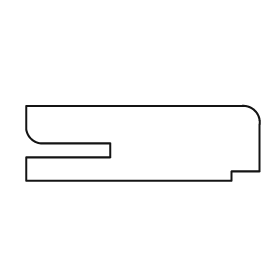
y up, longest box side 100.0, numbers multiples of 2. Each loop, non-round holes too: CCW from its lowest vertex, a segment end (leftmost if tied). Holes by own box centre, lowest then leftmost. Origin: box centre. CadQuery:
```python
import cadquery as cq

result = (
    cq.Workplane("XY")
    .moveTo(-50.0, -16.0)
    .lineTo(38.0, -16.0)
    .lineTo(38.0, -12.0)
    .lineTo(50.0, -12.0)
    .lineTo(50.0, 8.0)
    .threePointArc((48.0, 14.0), (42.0, 16.0))
    .lineTo(-50.0, 16.0)
    .lineTo(-50.0, 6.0)
    .threePointArc((-48.0, 2.0), (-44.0, 0.0))
    .lineTo(-14.0, 0.0)
    .lineTo(-14.0, -6.0)
    .lineTo(-50.0, -6.0)
    .close()
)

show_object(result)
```